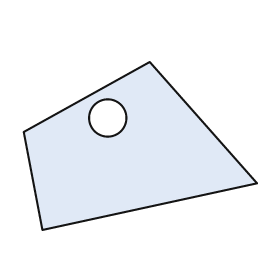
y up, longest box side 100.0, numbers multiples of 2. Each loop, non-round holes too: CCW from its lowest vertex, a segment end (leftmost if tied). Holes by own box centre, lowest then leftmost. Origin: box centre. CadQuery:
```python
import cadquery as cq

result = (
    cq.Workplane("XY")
    .moveTo(-42.0, -36.0)
    .lineTo(50.0, -16.0)
    .lineTo(4.0, 36.0)
    .lineTo(-50.0, 6.0)
    .close()
    .moveTo(-14.0, 12.0)
    .circle(8.0)
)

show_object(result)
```